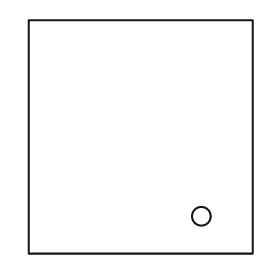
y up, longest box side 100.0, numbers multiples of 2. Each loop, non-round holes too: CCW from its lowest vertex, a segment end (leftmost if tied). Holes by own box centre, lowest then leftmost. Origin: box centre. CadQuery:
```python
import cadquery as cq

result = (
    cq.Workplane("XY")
    .moveTo(-48.0, -50.0)
    .lineTo(48.0, -50.0)
    .lineTo(48.0, 50.0)
    .lineTo(-48.0, 50.0)
    .close()
    .moveTo(26.0, -34.0)
    .circle(4.0)
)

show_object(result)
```